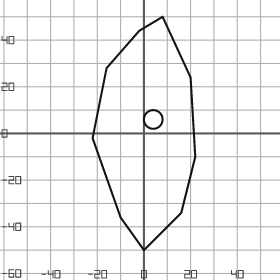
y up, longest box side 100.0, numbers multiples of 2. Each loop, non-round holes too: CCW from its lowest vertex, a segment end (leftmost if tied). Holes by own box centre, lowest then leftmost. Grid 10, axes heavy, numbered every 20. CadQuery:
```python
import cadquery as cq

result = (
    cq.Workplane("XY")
    .moveTo(0.0, -50.0)
    .lineTo(16.0, -34.0)
    .lineTo(22.0, -10.0)
    .lineTo(20.0, 24.0)
    .lineTo(8.0, 50.0)
    .lineTo(-2.0, 44.0)
    .lineTo(-16.0, 28.0)
    .lineTo(-22.0, -2.0)
    .lineTo(-10.0, -36.0)
    .close()
    .moveTo(4.0, 6.0)
    .circle(4.0)
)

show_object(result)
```